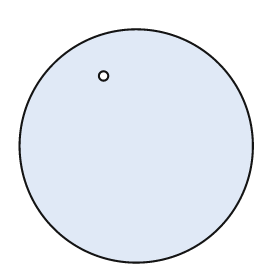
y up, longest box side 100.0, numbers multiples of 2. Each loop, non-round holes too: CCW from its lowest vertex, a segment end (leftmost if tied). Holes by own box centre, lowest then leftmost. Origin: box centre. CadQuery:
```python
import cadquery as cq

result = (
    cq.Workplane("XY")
    .moveTo(0.0, 0.0)
    .circle(50.0)
    .moveTo(-14.0, 30.0)
    .circle(2.0)
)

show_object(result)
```